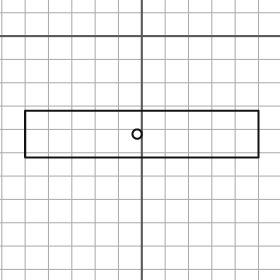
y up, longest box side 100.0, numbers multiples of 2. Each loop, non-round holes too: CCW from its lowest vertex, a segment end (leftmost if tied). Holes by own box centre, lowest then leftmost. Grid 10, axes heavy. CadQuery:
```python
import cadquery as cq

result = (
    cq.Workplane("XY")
    .moveTo(-50.0, -52.0)
    .lineTo(50.0, -52.0)
    .lineTo(50.0, -32.0)
    .lineTo(-50.0, -32.0)
    .close()
    .moveTo(-2.0, -42.0)
    .circle(2.0)
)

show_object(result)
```